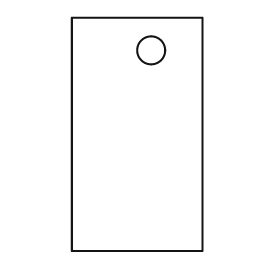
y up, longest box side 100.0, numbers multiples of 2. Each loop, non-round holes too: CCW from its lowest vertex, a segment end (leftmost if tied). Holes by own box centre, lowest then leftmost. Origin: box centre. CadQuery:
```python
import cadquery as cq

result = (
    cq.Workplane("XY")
    .moveTo(-28.0, -50.0)
    .lineTo(28.0, -50.0)
    .lineTo(28.0, 50.0)
    .lineTo(-28.0, 50.0)
    .close()
    .moveTo(6.0, 36.0)
    .circle(6.0)
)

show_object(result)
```